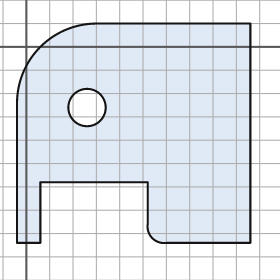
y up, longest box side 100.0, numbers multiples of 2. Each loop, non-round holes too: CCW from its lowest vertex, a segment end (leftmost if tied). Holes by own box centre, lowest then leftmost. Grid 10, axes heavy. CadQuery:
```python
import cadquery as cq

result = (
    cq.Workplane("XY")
    .moveTo(-4.0, -84.0)
    .lineTo(6.0, -84.0)
    .lineTo(6.0, -58.0)
    .lineTo(52.0, -58.0)
    .lineTo(52.0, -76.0)
    .threePointArc((54.0, -82.0), (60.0, -84.0))
    .lineTo(96.0, -84.0)
    .lineTo(96.0, 10.0)
    .lineTo(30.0, 10.0)
    .threePointArc((6.0, 0.0), (-4.0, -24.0))
    .close()
    .moveTo(26.0, -26.0)
    .circle(8.0)
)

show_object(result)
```